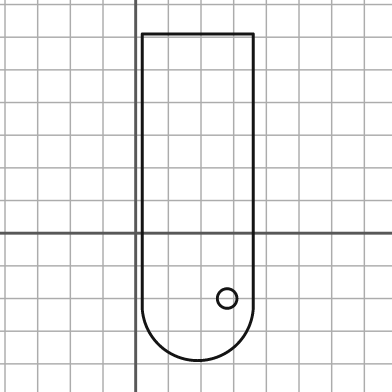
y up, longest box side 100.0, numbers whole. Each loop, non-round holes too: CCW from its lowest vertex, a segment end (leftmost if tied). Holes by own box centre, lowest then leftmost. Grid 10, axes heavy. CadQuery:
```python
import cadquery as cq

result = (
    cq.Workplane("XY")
    .moveTo(2.0, -23.0)
    .threePointArc((19.0, -39.0), (36.0, -23.0))
    .lineTo(36.0, 61.0)
    .lineTo(2.0, 61.0)
    .close()
    .moveTo(28.0, -20.0)
    .circle(3.0)
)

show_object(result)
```